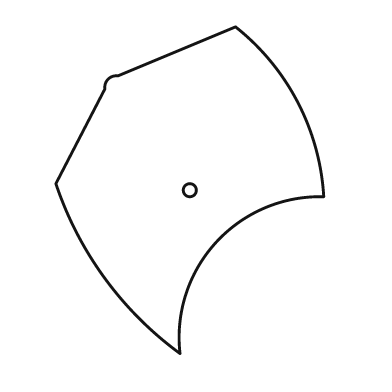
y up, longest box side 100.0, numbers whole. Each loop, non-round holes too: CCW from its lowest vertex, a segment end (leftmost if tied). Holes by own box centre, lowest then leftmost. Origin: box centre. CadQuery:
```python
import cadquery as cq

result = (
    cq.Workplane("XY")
    .moveTo(-3.0, -50.0)
    .threePointArc((8.0, -16.0), (41.0, -2.0))
    .threePointArc((33.0, 27.0), (14.0, 50.0))
    .lineTo(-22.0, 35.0)
    .threePointArc((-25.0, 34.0), (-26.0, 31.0))
    .lineTo(-41.0, 2.0)
    .threePointArc((-26.0, -27.0), (-3.0, -50.0))
    .close()
    .moveTo(0.0, 0.0)
    .circle(2.0)
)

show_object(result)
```